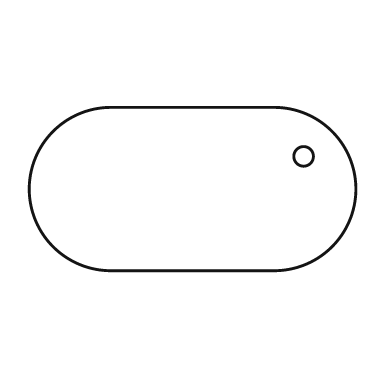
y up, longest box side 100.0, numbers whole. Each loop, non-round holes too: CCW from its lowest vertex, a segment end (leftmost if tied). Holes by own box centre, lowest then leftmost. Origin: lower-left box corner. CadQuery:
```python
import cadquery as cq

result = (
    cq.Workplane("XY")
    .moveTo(25.0, 0.0)
    .lineTo(75.0, 0.0)
    .threePointArc((100.0, 25.0), (75.0, 50.0))
    .lineTo(25.0, 50.0)
    .threePointArc((0.0, 25.0), (25.0, 0.0))
    .close()
    .moveTo(84.0, 35.0)
    .circle(3.0)
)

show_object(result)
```